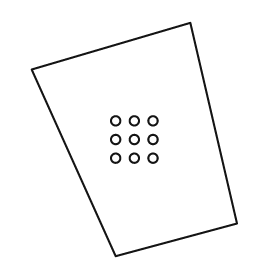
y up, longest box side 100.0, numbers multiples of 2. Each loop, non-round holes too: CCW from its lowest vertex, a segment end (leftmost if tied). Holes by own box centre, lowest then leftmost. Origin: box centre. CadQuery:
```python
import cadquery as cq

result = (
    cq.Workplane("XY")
    .moveTo(-8.0, -50.0)
    .lineTo(44.0, -36.0)
    .lineTo(24.0, 50.0)
    .lineTo(-44.0, 30.0)
    .close()
    .moveTo(-8.0, -8.0)
    .circle(2.0)
    .moveTo(0.0, -8.0)
    .circle(2.0)
    .moveTo(8.0, -8.0)
    .circle(2.0)
    .moveTo(-8.0, 0.0)
    .circle(2.0)
    .moveTo(0.0, 0.0)
    .circle(2.0)
    .moveTo(8.0, 0.0)
    .circle(2.0)
    .moveTo(-8.0, 8.0)
    .circle(2.0)
    .moveTo(0.0, 8.0)
    .circle(2.0)
    .moveTo(8.0, 8.0)
    .circle(2.0)
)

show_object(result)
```